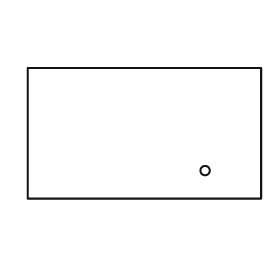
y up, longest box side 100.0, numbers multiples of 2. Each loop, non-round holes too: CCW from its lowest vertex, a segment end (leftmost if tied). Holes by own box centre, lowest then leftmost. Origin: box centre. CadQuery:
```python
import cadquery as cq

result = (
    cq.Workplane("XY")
    .moveTo(-50.0, -28.0)
    .lineTo(50.0, -28.0)
    .lineTo(50.0, 28.0)
    .lineTo(-50.0, 28.0)
    .close()
    .moveTo(26.0, -16.0)
    .circle(2.0)
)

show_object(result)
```